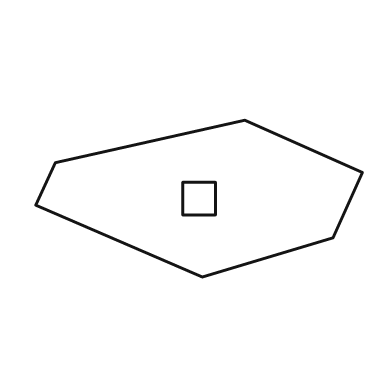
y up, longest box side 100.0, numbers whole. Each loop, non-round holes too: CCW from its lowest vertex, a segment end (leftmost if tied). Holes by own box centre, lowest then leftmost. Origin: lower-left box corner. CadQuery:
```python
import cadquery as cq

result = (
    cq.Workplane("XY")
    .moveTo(51.0, 0.0)
    .lineTo(91.0, 12.0)
    .lineTo(100.0, 32.0)
    .lineTo(64.0, 48.0)
    .lineTo(6.0, 35.0)
    .lineTo(0.0, 22.0)
    .close()
    .moveTo(45.0, 19.0)
    .lineTo(55.0, 19.0)
    .lineTo(55.0, 29.0)
    .lineTo(45.0, 29.0)
    .close()
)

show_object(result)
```